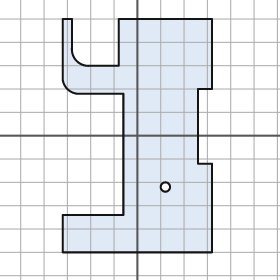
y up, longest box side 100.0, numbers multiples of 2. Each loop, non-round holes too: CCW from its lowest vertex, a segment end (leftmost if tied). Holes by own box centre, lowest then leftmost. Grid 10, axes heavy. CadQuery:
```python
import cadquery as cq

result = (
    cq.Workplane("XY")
    .moveTo(-32.0, -50.0)
    .lineTo(32.0, -50.0)
    .lineTo(32.0, -12.0)
    .lineTo(26.0, -12.0)
    .lineTo(26.0, 20.0)
    .lineTo(32.0, 20.0)
    .lineTo(32.0, 50.0)
    .lineTo(-8.0, 50.0)
    .lineTo(-8.0, 30.0)
    .lineTo(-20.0, 30.0)
    .threePointArc((-26.0, 32.0), (-28.0, 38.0))
    .lineTo(-28.0, 50.0)
    .lineTo(-32.0, 50.0)
    .lineTo(-32.0, 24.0)
    .threePointArc((-30.0, 20.0), (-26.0, 18.0))
    .lineTo(-6.0, 18.0)
    .lineTo(-6.0, -34.0)
    .lineTo(-32.0, -34.0)
    .close()
    .moveTo(12.0, -22.0)
    .circle(2.0)
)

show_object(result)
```